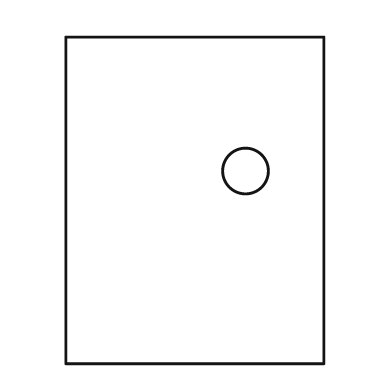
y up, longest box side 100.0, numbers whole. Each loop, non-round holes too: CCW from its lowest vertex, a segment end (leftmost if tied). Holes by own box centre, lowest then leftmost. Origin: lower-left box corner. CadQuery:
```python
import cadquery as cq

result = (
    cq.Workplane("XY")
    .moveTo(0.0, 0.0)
    .lineTo(79.0, 0.0)
    .lineTo(79.0, 100.0)
    .lineTo(0.0, 100.0)
    .close()
    .moveTo(55.0, 59.0)
    .circle(7.0)
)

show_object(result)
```